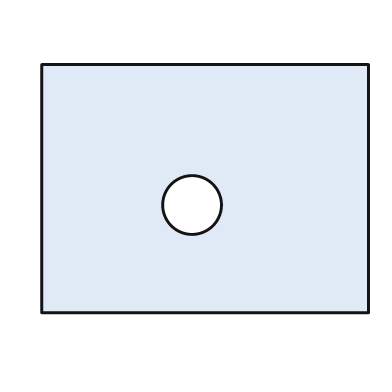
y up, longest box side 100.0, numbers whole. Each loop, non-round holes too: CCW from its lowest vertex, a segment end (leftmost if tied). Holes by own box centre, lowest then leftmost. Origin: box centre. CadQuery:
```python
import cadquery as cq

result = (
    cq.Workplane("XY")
    .moveTo(-50.0, -38.0)
    .lineTo(50.0, -38.0)
    .lineTo(50.0, 38.0)
    .lineTo(-50.0, 38.0)
    .close()
    .moveTo(-4.0, -5.0)
    .circle(9.0)
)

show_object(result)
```